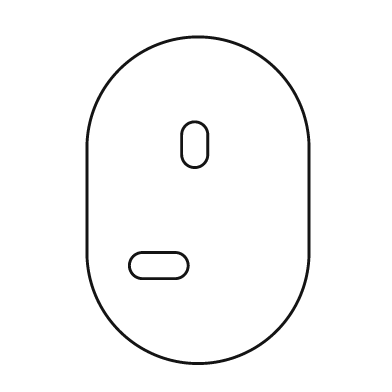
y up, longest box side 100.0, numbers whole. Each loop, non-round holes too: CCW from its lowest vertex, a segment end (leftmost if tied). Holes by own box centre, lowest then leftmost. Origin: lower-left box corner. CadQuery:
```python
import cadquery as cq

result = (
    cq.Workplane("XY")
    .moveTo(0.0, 34.0)
    .threePointArc((34.0, 0.0), (68.0, 34.0))
    .lineTo(68.0, 66.0)
    .threePointArc((34.0, 100.0), (0.0, 66.0))
    .close()
    .moveTo(17.0, 26.0)
    .lineTo(27.0, 26.0)
    .threePointArc((31.0, 30.0), (27.0, 34.0))
    .lineTo(17.0, 34.0)
    .threePointArc((13.0, 30.0), (17.0, 26.0))
    .close()
    .moveTo(29.0, 64.0)
    .threePointArc((33.0, 60.0), (37.0, 64.0))
    .lineTo(37.0, 70.0)
    .threePointArc((33.0, 74.0), (29.0, 70.0))
    .close()
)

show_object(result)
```